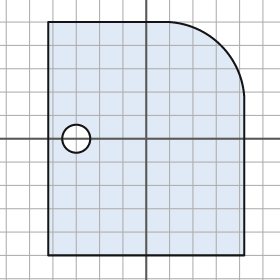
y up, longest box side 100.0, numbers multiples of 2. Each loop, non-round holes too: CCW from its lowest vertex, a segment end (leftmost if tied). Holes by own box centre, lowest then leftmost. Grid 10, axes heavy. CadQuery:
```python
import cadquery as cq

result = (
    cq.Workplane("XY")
    .moveTo(-42.0, -50.0)
    .lineTo(42.0, -50.0)
    .lineTo(42.0, 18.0)
    .threePointArc((32.0, 40.0), (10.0, 50.0))
    .lineTo(-42.0, 50.0)
    .close()
    .moveTo(-30.0, 0.0)
    .circle(6.0)
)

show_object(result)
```